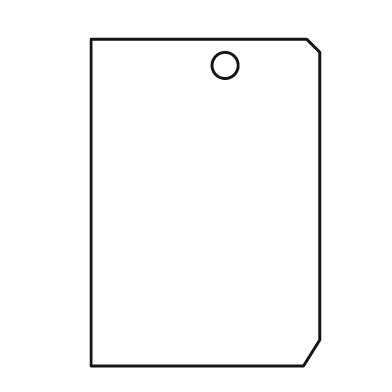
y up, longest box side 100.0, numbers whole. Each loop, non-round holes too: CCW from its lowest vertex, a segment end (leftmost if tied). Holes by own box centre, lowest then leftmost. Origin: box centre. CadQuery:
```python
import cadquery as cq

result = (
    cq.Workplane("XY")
    .moveTo(-35.0, -50.0)
    .lineTo(30.0, -50.0)
    .lineTo(35.0, -42.0)
    .lineTo(35.0, 46.0)
    .lineTo(31.0, 50.0)
    .lineTo(-35.0, 50.0)
    .close()
    .moveTo(6.0, 42.0)
    .circle(4.0)
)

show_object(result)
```